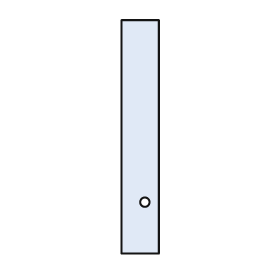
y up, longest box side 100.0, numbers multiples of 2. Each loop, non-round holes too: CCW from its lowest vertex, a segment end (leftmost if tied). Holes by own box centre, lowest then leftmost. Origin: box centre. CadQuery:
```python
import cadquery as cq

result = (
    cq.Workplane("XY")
    .moveTo(-8.0, -50.0)
    .lineTo(8.0, -50.0)
    .lineTo(8.0, 50.0)
    .lineTo(-8.0, 50.0)
    .close()
    .moveTo(2.0, -28.0)
    .circle(2.0)
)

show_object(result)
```